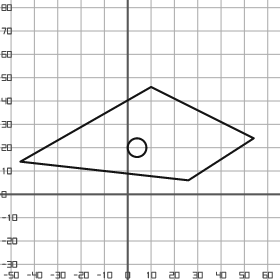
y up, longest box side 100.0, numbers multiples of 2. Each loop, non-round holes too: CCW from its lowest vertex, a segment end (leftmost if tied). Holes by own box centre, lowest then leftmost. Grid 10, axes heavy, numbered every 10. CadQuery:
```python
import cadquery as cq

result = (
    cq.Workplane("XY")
    .moveTo(26.0, 6.0)
    .lineTo(54.0, 24.0)
    .lineTo(10.0, 46.0)
    .lineTo(-46.0, 14.0)
    .close()
    .moveTo(4.0, 20.0)
    .circle(4.0)
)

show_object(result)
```